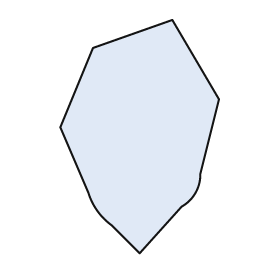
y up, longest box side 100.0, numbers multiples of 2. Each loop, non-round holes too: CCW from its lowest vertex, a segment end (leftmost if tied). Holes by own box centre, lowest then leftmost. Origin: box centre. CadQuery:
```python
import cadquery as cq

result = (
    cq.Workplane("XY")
    .moveTo(0.0, -50.0)
    .lineTo(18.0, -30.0)
    .threePointArc((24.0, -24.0), (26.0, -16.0))
    .lineTo(34.0, 16.0)
    .lineTo(14.0, 50.0)
    .lineTo(-20.0, 38.0)
    .lineTo(-34.0, 4.0)
    .lineTo(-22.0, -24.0)
    .threePointArc((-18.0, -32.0), (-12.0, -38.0))
    .close()
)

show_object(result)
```